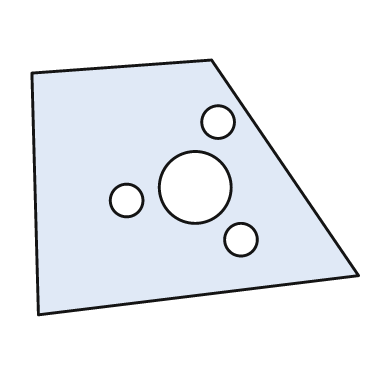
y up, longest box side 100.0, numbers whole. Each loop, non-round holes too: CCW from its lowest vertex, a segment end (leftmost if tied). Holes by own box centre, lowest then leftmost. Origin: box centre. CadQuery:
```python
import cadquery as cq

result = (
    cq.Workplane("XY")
    .moveTo(-48.0, -39.0)
    .lineTo(50.0, -27.0)
    .lineTo(5.0, 39.0)
    .lineTo(-50.0, 35.0)
    .close()
    .moveTo(14.0, -16.0)
    .circle(5.0)
    .moveTo(-21.0, -4.0)
    .circle(5.0)
    .moveTo(0.0, 0.0)
    .circle(11.0)
    .moveTo(7.0, 20.0)
    .circle(5.0)
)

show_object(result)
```